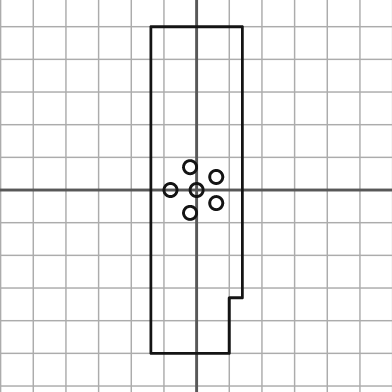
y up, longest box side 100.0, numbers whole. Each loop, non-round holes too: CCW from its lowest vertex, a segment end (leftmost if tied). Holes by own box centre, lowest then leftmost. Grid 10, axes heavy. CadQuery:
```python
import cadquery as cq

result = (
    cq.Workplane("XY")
    .moveTo(-14.0, -50.0)
    .lineTo(10.0, -50.0)
    .lineTo(10.0, -33.0)
    .lineTo(14.0, -33.0)
    .lineTo(14.0, 50.0)
    .lineTo(-14.0, 50.0)
    .close()
    .moveTo(-2.0, -7.0)
    .circle(2.0)
    .moveTo(6.0, -4.0)
    .circle(2.0)
    .moveTo(-8.0, 0.0)
    .circle(2.0)
    .moveTo(0.0, 0.0)
    .circle(2.0)
    .moveTo(6.0, 4.0)
    .circle(2.0)
    .moveTo(-2.0, 7.0)
    .circle(2.0)
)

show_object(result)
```